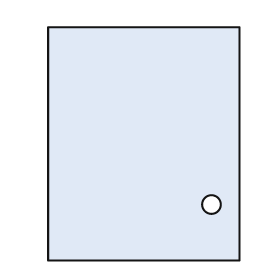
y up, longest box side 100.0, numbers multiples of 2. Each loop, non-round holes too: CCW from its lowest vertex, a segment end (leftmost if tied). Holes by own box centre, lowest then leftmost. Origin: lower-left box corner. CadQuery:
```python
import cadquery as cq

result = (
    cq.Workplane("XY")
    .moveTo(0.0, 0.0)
    .lineTo(82.0, 0.0)
    .lineTo(82.0, 100.0)
    .lineTo(0.0, 100.0)
    .close()
    .moveTo(70.0, 24.0)
    .circle(4.0)
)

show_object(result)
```